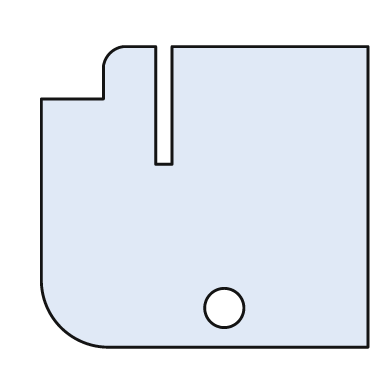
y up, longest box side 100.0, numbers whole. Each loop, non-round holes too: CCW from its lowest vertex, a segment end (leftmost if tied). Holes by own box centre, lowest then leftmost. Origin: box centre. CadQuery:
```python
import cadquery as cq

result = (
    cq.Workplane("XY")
    .moveTo(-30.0, -46.0)
    .lineTo(50.0, -46.0)
    .lineTo(50.0, 46.0)
    .lineTo(-10.0, 46.0)
    .lineTo(-10.0, 10.0)
    .lineTo(-15.0, 10.0)
    .lineTo(-15.0, 46.0)
    .lineTo(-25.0, 46.0)
    .threePointArc((-29.0, 44.0), (-31.0, 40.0))
    .lineTo(-31.0, 30.0)
    .lineTo(-50.0, 30.0)
    .lineTo(-50.0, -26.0)
    .threePointArc((-44.0, -40.0), (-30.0, -46.0))
    .close()
    .moveTo(6.0, -34.0)
    .circle(6.0)
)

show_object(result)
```